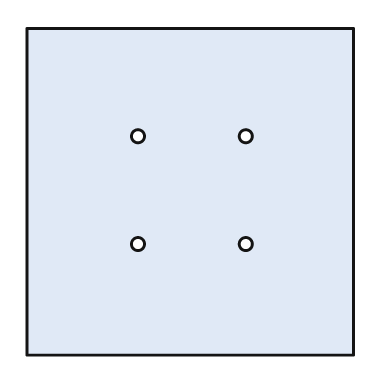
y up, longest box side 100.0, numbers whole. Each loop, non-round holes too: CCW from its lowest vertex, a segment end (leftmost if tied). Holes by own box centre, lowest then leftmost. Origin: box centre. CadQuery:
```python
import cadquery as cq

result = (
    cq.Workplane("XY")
    .moveTo(-50.0, -50.0)
    .lineTo(50.0, -50.0)
    .lineTo(50.0, 50.0)
    .lineTo(-50.0, 50.0)
    .close()
    .moveTo(-16.0, -16.0)
    .circle(2.0)
    .moveTo(17.0, -16.0)
    .circle(2.0)
    .moveTo(-16.0, 17.0)
    .circle(2.0)
    .moveTo(17.0, 17.0)
    .circle(2.0)
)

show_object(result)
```